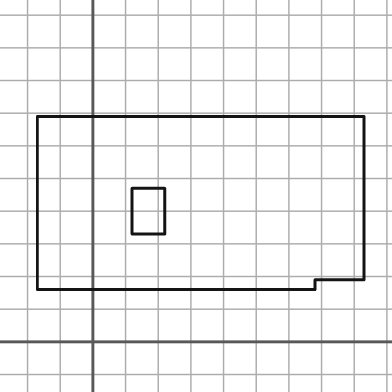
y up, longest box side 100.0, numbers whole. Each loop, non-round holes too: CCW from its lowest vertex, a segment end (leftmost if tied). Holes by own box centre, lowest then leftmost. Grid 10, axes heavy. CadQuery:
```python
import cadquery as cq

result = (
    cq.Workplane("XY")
    .moveTo(-17.0, 16.0)
    .lineTo(68.0, 16.0)
    .lineTo(68.0, 19.0)
    .lineTo(83.0, 19.0)
    .lineTo(83.0, 69.0)
    .lineTo(-17.0, 69.0)
    .close()
    .moveTo(12.0, 33.0)
    .lineTo(22.0, 33.0)
    .lineTo(22.0, 47.0)
    .lineTo(12.0, 47.0)
    .close()
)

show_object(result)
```